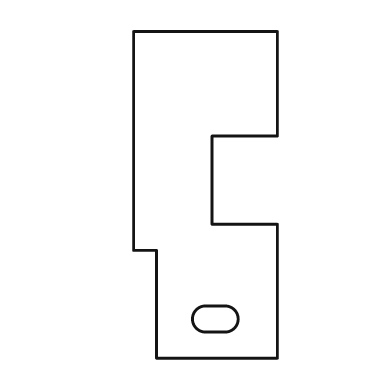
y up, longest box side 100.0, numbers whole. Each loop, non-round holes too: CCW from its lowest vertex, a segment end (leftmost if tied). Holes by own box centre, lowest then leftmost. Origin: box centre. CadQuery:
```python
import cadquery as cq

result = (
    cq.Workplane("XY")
    .moveTo(-15.0, -50.0)
    .lineTo(22.0, -50.0)
    .lineTo(22.0, -9.0)
    .lineTo(2.0, -9.0)
    .lineTo(2.0, 18.0)
    .lineTo(22.0, 18.0)
    .lineTo(22.0, 50.0)
    .lineTo(-22.0, 50.0)
    .lineTo(-22.0, -17.0)
    .lineTo(-15.0, -17.0)
    .close()
    .moveTo(0.0, -42.0)
    .lineTo(6.0, -42.0)
    .threePointArc((10.0, -38.0), (6.0, -34.0))
    .lineTo(0.0, -34.0)
    .threePointArc((-4.0, -38.0), (0.0, -42.0))
    .close()
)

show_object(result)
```